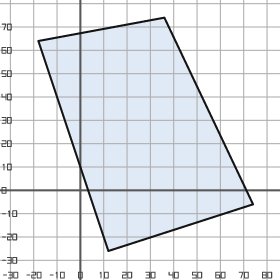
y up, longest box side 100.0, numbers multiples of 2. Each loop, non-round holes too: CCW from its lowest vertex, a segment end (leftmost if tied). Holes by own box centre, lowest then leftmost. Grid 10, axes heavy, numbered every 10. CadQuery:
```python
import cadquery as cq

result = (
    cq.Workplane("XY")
    .moveTo(12.0, -26.0)
    .lineTo(74.0, -6.0)
    .lineTo(36.0, 74.0)
    .lineTo(-18.0, 64.0)
    .close()
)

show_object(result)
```